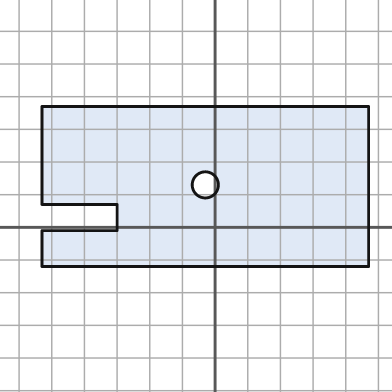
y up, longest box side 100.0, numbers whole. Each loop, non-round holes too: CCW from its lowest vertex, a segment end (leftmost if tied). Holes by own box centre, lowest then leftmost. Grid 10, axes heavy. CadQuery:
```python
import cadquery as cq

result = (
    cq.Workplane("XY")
    .moveTo(-53.0, -12.0)
    .lineTo(47.0, -12.0)
    .lineTo(47.0, 37.0)
    .lineTo(-53.0, 37.0)
    .lineTo(-53.0, 7.0)
    .lineTo(-30.0, 7.0)
    .lineTo(-30.0, -1.0)
    .lineTo(-53.0, -1.0)
    .close()
    .moveTo(-3.0, 13.0)
    .circle(4.0)
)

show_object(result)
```